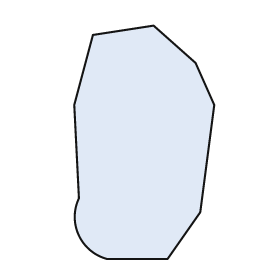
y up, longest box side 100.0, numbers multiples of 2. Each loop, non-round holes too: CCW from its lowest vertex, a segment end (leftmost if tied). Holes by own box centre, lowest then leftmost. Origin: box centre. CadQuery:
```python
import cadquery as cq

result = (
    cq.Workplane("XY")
    .moveTo(-16.0, -50.0)
    .lineTo(10.0, -50.0)
    .lineTo(24.0, -30.0)
    .lineTo(30.0, 16.0)
    .lineTo(22.0, 34.0)
    .lineTo(4.0, 50.0)
    .lineTo(-22.0, 46.0)
    .lineTo(-30.0, 16.0)
    .lineTo(-28.0, -24.0)
    .threePointArc((-28.0, -40.0), (-16.0, -50.0))
    .close()
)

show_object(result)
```